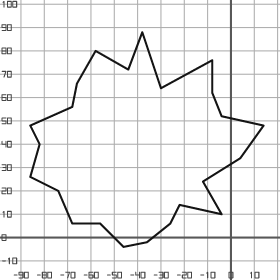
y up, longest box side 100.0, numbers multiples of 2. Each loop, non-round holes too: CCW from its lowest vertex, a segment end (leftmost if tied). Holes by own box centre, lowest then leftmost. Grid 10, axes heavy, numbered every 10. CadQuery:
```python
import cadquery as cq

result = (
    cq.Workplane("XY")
    .moveTo(-46.0, -4.0)
    .lineTo(-36.0, -2.0)
    .lineTo(-26.0, 6.0)
    .lineTo(-22.0, 14.0)
    .lineTo(-4.0, 10.0)
    .lineTo(-12.0, 24.0)
    .lineTo(4.0, 34.0)
    .lineTo(14.0, 48.0)
    .lineTo(-4.0, 52.0)
    .lineTo(-8.0, 62.0)
    .lineTo(-8.0, 76.0)
    .lineTo(-30.0, 64.0)
    .lineTo(-38.0, 88.0)
    .lineTo(-44.0, 72.0)
    .lineTo(-58.0, 80.0)
    .lineTo(-66.0, 66.0)
    .lineTo(-68.0, 56.0)
    .lineTo(-86.0, 48.0)
    .lineTo(-82.0, 40.0)
    .lineTo(-86.0, 26.0)
    .lineTo(-74.0, 20.0)
    .lineTo(-68.0, 6.0)
    .lineTo(-56.0, 6.0)
    .close()
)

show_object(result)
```